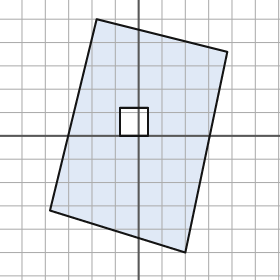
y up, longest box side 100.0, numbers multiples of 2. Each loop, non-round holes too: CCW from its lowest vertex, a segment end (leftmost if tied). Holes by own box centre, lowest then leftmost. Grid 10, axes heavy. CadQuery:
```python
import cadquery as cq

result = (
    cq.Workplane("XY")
    .moveTo(20.0, -50.0)
    .lineTo(38.0, 36.0)
    .lineTo(-18.0, 50.0)
    .lineTo(-38.0, -32.0)
    .close()
    .moveTo(-8.0, 0.0)
    .lineTo(4.0, 0.0)
    .lineTo(4.0, 12.0)
    .lineTo(-8.0, 12.0)
    .close()
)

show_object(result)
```